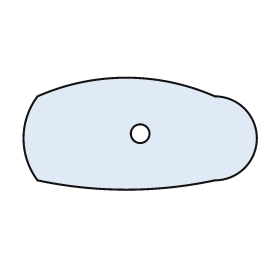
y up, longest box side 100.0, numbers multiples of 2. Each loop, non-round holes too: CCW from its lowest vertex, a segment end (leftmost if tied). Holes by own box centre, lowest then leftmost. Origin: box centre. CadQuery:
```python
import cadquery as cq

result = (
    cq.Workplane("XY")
    .moveTo(-44.0, -20.0)
    .threePointArc((-6.0, -24.0), (32.0, -20.0))
    .threePointArc((50.0, -2.0), (32.0, 16.0))
    .threePointArc((-6.0, 24.0), (-44.0, 16.0))
    .threePointArc((-50.0, -2.0), (-44.0, -20.0))
    .close()
    .moveTo(0.0, 0.0)
    .circle(4.0)
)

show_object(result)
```